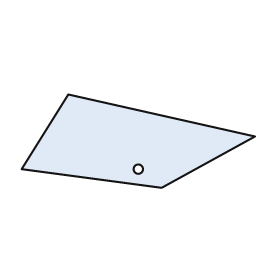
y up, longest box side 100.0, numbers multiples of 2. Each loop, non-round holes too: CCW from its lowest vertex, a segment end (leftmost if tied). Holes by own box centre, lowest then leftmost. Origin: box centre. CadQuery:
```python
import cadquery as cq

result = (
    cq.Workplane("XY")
    .moveTo(10.0, -20.0)
    .lineTo(50.0, 2.0)
    .lineTo(-30.0, 20.0)
    .lineTo(-50.0, -12.0)
    .close()
    .moveTo(0.0, -12.0)
    .circle(2.0)
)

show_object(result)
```